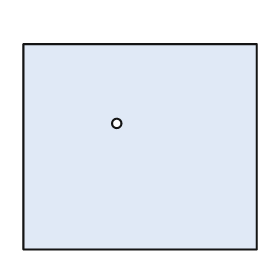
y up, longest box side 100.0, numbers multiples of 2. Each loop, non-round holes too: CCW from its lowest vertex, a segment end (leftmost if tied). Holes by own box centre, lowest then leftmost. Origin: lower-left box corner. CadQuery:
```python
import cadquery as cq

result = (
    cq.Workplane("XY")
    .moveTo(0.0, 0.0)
    .lineTo(100.0, 0.0)
    .lineTo(100.0, 88.0)
    .lineTo(0.0, 88.0)
    .close()
    .moveTo(40.0, 54.0)
    .circle(2.0)
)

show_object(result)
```